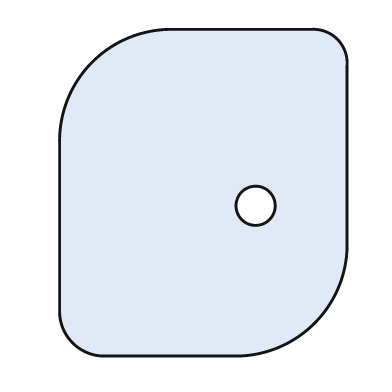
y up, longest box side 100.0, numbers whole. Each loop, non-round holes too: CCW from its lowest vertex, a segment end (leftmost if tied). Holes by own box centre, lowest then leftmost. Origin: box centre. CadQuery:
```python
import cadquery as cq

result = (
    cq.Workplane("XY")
    .moveTo(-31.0, -50.0)
    .lineTo(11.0, -50.0)
    .threePointArc((34.0, -40.0), (44.0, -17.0))
    .lineTo(44.0, 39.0)
    .threePointArc((41.0, 47.0), (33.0, 50.0))
    .lineTo(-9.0, 50.0)
    .threePointArc((-34.0, 40.0), (-44.0, 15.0))
    .lineTo(-44.0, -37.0)
    .threePointArc((-40.0, -46.0), (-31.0, -50.0))
    .close()
    .moveTo(16.0, -4.0)
    .circle(6.0)
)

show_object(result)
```